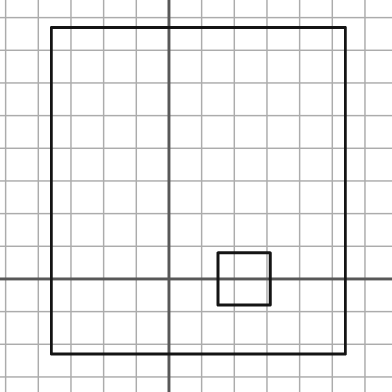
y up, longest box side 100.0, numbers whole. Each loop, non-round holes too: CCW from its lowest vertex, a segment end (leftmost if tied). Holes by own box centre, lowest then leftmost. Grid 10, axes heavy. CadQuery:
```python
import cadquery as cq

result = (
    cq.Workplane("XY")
    .moveTo(-36.0, -23.0)
    .lineTo(54.0, -23.0)
    .lineTo(54.0, 77.0)
    .lineTo(-36.0, 77.0)
    .close()
    .moveTo(15.0, -8.0)
    .lineTo(31.0, -8.0)
    .lineTo(31.0, 8.0)
    .lineTo(15.0, 8.0)
    .close()
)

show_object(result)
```